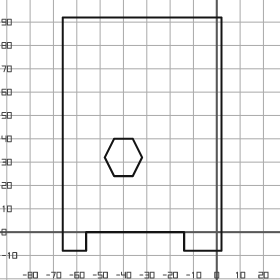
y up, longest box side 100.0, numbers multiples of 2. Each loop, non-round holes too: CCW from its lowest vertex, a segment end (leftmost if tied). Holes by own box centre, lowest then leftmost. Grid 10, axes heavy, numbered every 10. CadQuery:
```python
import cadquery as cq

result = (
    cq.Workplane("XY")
    .moveTo(-66.0, -8.0)
    .lineTo(-56.0, -8.0)
    .lineTo(-56.0, 0.0)
    .lineTo(-14.0, 0.0)
    .lineTo(-14.0, -8.0)
    .lineTo(2.0, -8.0)
    .lineTo(2.0, 92.0)
    .lineTo(-66.0, 92.0)
    .close()
    .moveTo(-44.0, 24.0)
    .lineTo(-36.0, 24.0)
    .lineTo(-32.0, 32.0)
    .lineTo(-36.0, 40.0)
    .lineTo(-44.0, 40.0)
    .lineTo(-48.0, 32.0)
    .close()
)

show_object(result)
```